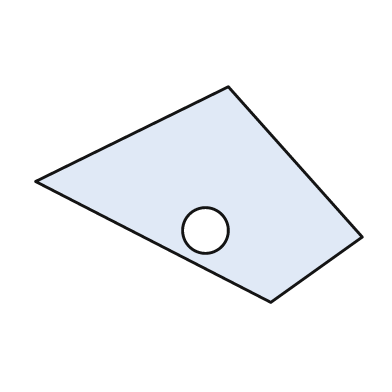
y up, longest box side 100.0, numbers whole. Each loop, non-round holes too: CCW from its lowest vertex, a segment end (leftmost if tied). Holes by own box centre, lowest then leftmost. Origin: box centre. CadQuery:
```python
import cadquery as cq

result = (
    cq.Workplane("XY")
    .moveTo(22.0, -33.0)
    .lineTo(50.0, -13.0)
    .lineTo(9.0, 33.0)
    .lineTo(-50.0, 4.0)
    .close()
    .moveTo(2.0, -11.0)
    .circle(7.0)
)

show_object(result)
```